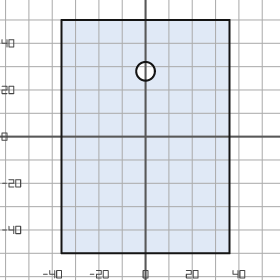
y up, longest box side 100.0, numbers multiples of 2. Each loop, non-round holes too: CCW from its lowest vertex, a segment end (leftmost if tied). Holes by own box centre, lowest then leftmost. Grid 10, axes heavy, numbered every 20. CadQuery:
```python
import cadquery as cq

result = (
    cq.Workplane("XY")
    .moveTo(-36.0, -50.0)
    .lineTo(36.0, -50.0)
    .lineTo(36.0, 50.0)
    .lineTo(-36.0, 50.0)
    .close()
    .moveTo(0.0, 28.0)
    .circle(4.0)
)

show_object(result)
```